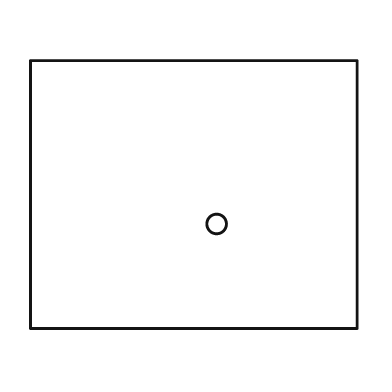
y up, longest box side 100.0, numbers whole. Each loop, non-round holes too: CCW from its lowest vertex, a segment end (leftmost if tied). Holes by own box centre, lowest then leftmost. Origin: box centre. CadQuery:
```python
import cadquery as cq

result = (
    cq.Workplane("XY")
    .moveTo(-50.0, -41.0)
    .lineTo(50.0, -41.0)
    .lineTo(50.0, 41.0)
    .lineTo(-50.0, 41.0)
    .close()
    .moveTo(7.0, -9.0)
    .circle(3.0)
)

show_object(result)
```